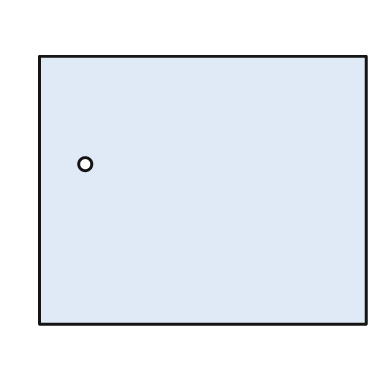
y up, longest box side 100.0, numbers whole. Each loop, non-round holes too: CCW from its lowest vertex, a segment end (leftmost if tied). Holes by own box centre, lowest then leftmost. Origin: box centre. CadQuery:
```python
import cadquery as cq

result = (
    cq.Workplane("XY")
    .moveTo(-50.0, -41.0)
    .lineTo(50.0, -41.0)
    .lineTo(50.0, 41.0)
    .lineTo(-50.0, 41.0)
    .close()
    .moveTo(-36.0, 8.0)
    .circle(2.0)
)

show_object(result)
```